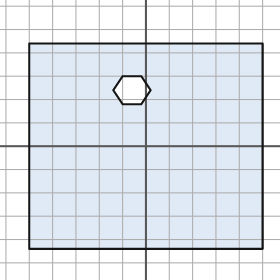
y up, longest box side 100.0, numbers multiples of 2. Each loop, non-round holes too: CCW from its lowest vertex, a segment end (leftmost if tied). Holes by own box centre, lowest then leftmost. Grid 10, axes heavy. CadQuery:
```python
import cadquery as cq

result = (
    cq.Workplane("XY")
    .moveTo(-50.0, -44.0)
    .lineTo(50.0, -44.0)
    .lineTo(50.0, 44.0)
    .lineTo(-50.0, 44.0)
    .close()
    .moveTo(-10.0, 18.0)
    .lineTo(-2.0, 18.0)
    .lineTo(2.0, 24.0)
    .lineTo(-2.0, 30.0)
    .lineTo(-10.0, 30.0)
    .lineTo(-14.0, 24.0)
    .close()
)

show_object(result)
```